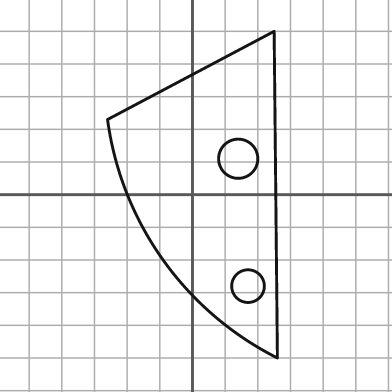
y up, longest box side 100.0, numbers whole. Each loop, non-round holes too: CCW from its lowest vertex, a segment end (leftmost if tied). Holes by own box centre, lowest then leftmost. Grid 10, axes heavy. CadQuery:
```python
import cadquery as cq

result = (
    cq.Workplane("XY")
    .moveTo(26.0, -50.0)
    .lineTo(25.0, 50.0)
    .lineTo(-26.0, 23.0)
    .threePointArc((-9.0, -20.0), (26.0, -50.0))
    .close()
    .moveTo(17.0, -28.0)
    .circle(5.0)
    .moveTo(14.0, 11.0)
    .circle(6.0)
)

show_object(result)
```